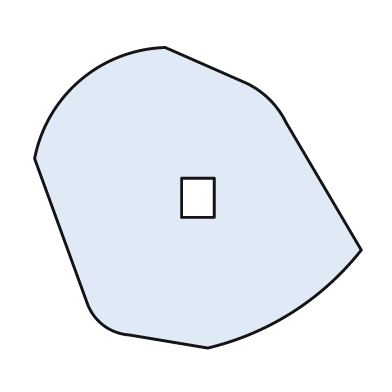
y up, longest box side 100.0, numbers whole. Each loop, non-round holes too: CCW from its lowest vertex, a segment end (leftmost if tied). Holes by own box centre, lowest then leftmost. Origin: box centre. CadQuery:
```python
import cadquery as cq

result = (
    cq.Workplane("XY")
    .moveTo(3.0, -46.0)
    .threePointArc((29.0, -35.0), (50.0, -16.0))
    .lineTo(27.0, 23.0)
    .threePointArc((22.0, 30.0), (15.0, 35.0))
    .lineTo(-10.0, 46.0)
    .threePointArc((-36.0, 36.0), (-50.0, 12.0))
    .lineTo(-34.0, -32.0)
    .threePointArc((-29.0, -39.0), (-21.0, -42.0))
    .close()
    .moveTo(-5.0, -6.0)
    .lineTo(5.0, -6.0)
    .lineTo(5.0, 6.0)
    .lineTo(-5.0, 6.0)
    .close()
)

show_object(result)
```